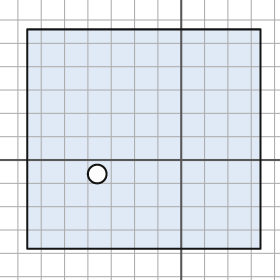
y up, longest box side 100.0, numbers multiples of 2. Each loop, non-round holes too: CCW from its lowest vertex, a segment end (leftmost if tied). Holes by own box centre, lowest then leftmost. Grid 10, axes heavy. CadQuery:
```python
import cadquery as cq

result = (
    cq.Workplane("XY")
    .moveTo(-66.0, -38.0)
    .lineTo(34.0, -38.0)
    .lineTo(34.0, 56.0)
    .lineTo(-66.0, 56.0)
    .close()
    .moveTo(-36.0, -6.0)
    .circle(4.0)
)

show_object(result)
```